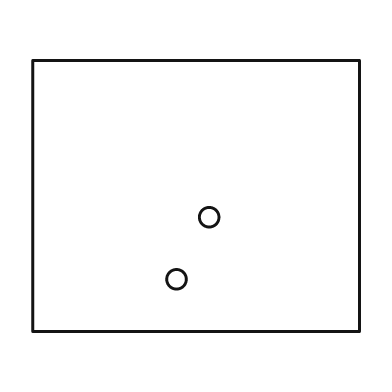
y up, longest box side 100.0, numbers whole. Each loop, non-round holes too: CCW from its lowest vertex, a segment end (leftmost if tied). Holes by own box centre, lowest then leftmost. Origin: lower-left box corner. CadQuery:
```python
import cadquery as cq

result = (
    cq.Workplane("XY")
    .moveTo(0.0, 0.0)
    .lineTo(100.0, 0.0)
    .lineTo(100.0, 83.0)
    .lineTo(0.0, 83.0)
    .close()
    .moveTo(44.0, 16.0)
    .circle(3.0)
    .moveTo(54.0, 35.0)
    .circle(3.0)
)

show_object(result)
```